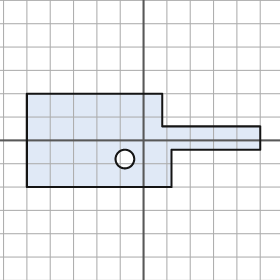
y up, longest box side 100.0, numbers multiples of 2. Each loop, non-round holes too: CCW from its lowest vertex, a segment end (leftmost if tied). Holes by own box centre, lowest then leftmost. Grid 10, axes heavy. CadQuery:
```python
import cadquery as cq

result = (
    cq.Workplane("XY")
    .moveTo(-50.0, -20.0)
    .lineTo(12.0, -20.0)
    .lineTo(12.0, -4.0)
    .lineTo(50.0, -4.0)
    .lineTo(50.0, 6.0)
    .lineTo(8.0, 6.0)
    .lineTo(8.0, 20.0)
    .lineTo(-50.0, 20.0)
    .close()
    .moveTo(-8.0, -8.0)
    .circle(4.0)
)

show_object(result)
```